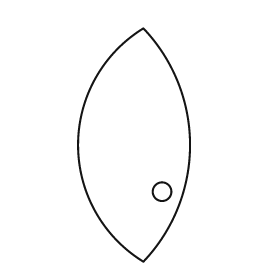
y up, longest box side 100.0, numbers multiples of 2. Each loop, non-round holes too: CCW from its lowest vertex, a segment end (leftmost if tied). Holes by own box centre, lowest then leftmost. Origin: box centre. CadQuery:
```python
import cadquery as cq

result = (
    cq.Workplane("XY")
    .moveTo(4.0, -50.0)
    .threePointArc((24.0, 0.0), (4.0, 50.0))
    .threePointArc((-24.0, 0.0), (4.0, -50.0))
    .close()
    .moveTo(12.0, -20.0)
    .circle(4.0)
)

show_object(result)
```